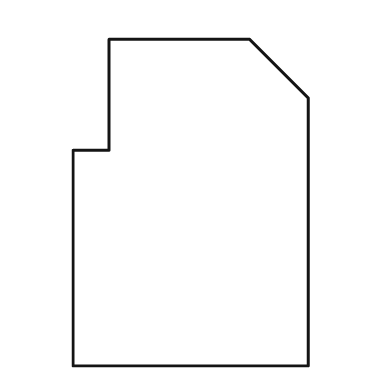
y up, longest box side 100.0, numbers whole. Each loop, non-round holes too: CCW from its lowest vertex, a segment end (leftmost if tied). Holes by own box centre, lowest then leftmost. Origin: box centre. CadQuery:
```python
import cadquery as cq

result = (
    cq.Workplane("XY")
    .moveTo(-36.0, -50.0)
    .lineTo(36.0, -50.0)
    .lineTo(36.0, 32.0)
    .lineTo(18.0, 50.0)
    .lineTo(-25.0, 50.0)
    .lineTo(-25.0, 16.0)
    .lineTo(-36.0, 16.0)
    .close()
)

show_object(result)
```